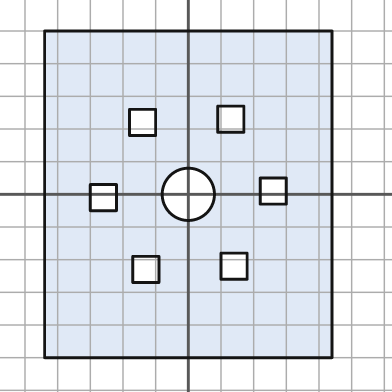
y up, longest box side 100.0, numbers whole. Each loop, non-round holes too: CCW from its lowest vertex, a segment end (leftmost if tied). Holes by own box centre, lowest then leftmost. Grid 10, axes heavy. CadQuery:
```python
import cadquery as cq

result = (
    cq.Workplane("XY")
    .moveTo(-44.0, -50.0)
    .lineTo(44.0, -50.0)
    .lineTo(44.0, 50.0)
    .lineTo(-44.0, 50.0)
    .close()
    .moveTo(-17.0, -27.0)
    .lineTo(-9.0, -27.0)
    .lineTo(-9.0, -19.0)
    .lineTo(-17.0, -19.0)
    .close()
    .moveTo(10.0, -26.0)
    .lineTo(18.0, -26.0)
    .lineTo(18.0, -18.0)
    .lineTo(10.0, -18.0)
    .close()
    .moveTo(-30.0, -5.0)
    .lineTo(-22.0, -5.0)
    .lineTo(-22.0, 3.0)
    .lineTo(-30.0, 3.0)
    .close()
    .moveTo(0.0, 0.0)
    .circle(8.0)
    .moveTo(22.0, -3.0)
    .lineTo(30.0, -3.0)
    .lineTo(30.0, 5.0)
    .lineTo(22.0, 5.0)
    .close()
    .moveTo(-18.0, 18.0)
    .lineTo(-10.0, 18.0)
    .lineTo(-10.0, 26.0)
    .lineTo(-18.0, 26.0)
    .close()
    .moveTo(9.0, 19.0)
    .lineTo(17.0, 19.0)
    .lineTo(17.0, 27.0)
    .lineTo(9.0, 27.0)
    .close()
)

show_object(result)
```